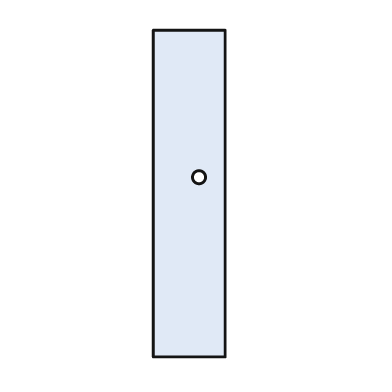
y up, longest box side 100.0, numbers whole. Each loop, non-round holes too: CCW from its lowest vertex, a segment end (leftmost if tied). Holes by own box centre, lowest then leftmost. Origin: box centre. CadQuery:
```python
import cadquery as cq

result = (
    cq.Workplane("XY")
    .moveTo(-11.0, -50.0)
    .lineTo(11.0, -50.0)
    .lineTo(11.0, 50.0)
    .lineTo(-11.0, 50.0)
    .close()
    .moveTo(3.0, 5.0)
    .circle(2.0)
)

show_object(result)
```